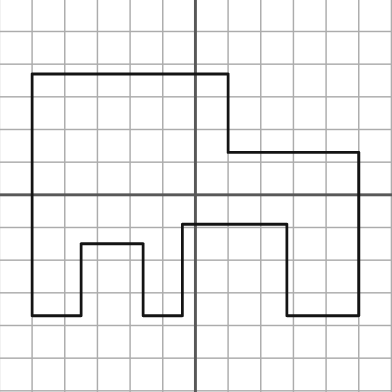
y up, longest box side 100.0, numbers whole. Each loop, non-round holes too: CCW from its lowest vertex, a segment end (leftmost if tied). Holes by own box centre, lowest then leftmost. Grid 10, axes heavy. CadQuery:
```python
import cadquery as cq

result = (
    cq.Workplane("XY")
    .moveTo(-50.0, -37.0)
    .lineTo(-35.0, -37.0)
    .lineTo(-35.0, -15.0)
    .lineTo(-16.0, -15.0)
    .lineTo(-16.0, -37.0)
    .lineTo(-4.0, -37.0)
    .lineTo(-4.0, -9.0)
    .lineTo(28.0, -9.0)
    .lineTo(28.0, -37.0)
    .lineTo(50.0, -37.0)
    .lineTo(50.0, 13.0)
    .lineTo(10.0, 13.0)
    .lineTo(10.0, 37.0)
    .lineTo(-50.0, 37.0)
    .close()
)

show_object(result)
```